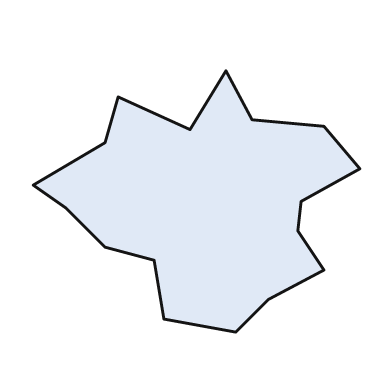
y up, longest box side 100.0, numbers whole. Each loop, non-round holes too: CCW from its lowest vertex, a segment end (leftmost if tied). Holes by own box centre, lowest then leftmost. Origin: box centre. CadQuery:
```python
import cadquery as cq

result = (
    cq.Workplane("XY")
    .moveTo(12.0, -40.0)
    .lineTo(22.0, -30.0)
    .lineTo(39.0, -21.0)
    .lineTo(31.0, -9.0)
    .lineTo(32.0, 0.0)
    .lineTo(50.0, 10.0)
    .lineTo(39.0, 23.0)
    .lineTo(17.0, 25.0)
    .lineTo(9.0, 40.0)
    .lineTo(-2.0, 22.0)
    .lineTo(-24.0, 32.0)
    .lineTo(-28.0, 18.0)
    .lineTo(-50.0, 5.0)
    .lineTo(-40.0, -2.0)
    .lineTo(-28.0, -14.0)
    .lineTo(-13.0, -18.0)
    .lineTo(-10.0, -36.0)
    .close()
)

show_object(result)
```